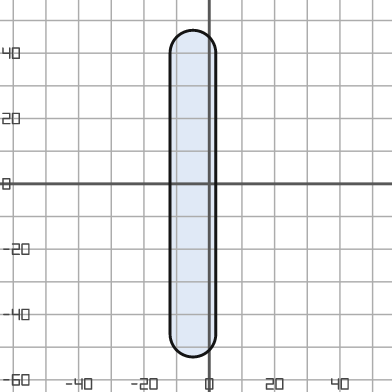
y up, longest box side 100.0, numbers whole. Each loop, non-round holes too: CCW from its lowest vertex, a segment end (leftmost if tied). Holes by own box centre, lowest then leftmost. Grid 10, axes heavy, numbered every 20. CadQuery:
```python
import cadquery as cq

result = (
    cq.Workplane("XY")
    .moveTo(-12.0, -46.0)
    .threePointArc((-5.0, -53.0), (2.0, -46.0))
    .lineTo(2.0, 40.0)
    .threePointArc((-5.0, 47.0), (-12.0, 40.0))
    .close()
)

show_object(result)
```